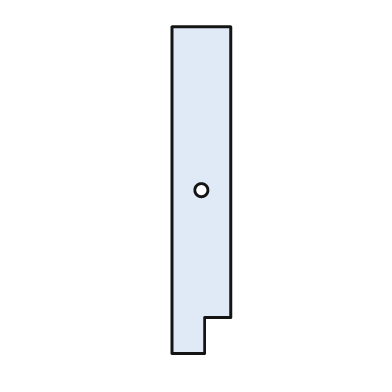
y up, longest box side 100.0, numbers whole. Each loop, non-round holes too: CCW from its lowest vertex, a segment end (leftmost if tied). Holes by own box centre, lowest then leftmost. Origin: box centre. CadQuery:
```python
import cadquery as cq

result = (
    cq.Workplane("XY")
    .moveTo(-9.0, -50.0)
    .lineTo(1.0, -50.0)
    .lineTo(1.0, -39.0)
    .lineTo(9.0, -39.0)
    .lineTo(9.0, 50.0)
    .lineTo(-9.0, 50.0)
    .close()
    .moveTo(0.0, 0.0)
    .circle(2.0)
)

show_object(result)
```